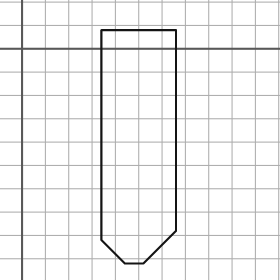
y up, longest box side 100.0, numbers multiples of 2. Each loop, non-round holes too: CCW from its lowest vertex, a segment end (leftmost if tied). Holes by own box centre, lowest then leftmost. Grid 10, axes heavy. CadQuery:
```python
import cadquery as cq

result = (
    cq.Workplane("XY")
    .moveTo(44.0, -92.0)
    .lineTo(52.0, -92.0)
    .lineTo(66.0, -78.0)
    .lineTo(66.0, 8.0)
    .lineTo(34.0, 8.0)
    .lineTo(34.0, -82.0)
    .close()
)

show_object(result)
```